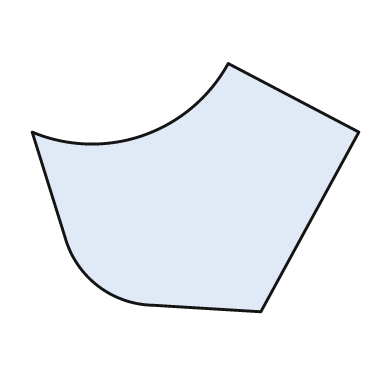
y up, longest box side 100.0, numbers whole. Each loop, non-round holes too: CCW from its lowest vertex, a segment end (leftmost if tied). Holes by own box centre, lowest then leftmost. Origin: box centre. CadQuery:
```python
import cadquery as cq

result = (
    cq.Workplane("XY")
    .moveTo(20.0, -38.0)
    .lineTo(50.0, 17.0)
    .lineTo(10.0, 38.0)
    .threePointArc((-16.0, 16.0), (-50.0, 17.0))
    .lineTo(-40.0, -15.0)
    .threePointArc((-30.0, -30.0), (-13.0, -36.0))
    .close()
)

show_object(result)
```